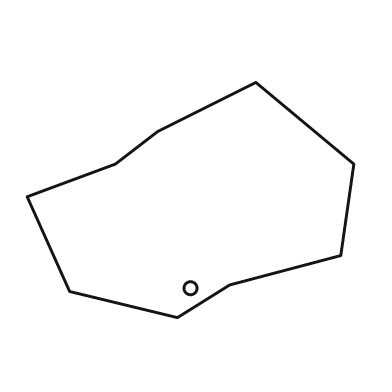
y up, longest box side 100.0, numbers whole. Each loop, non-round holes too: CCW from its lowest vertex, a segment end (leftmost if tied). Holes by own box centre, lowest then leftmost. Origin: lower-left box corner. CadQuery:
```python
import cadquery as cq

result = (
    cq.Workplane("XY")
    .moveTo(46.0, 0.0)
    .lineTo(62.0, 10.0)
    .lineTo(96.0, 19.0)
    .lineTo(100.0, 47.0)
    .lineTo(70.0, 72.0)
    .lineTo(40.0, 57.0)
    .lineTo(27.0, 47.0)
    .lineTo(0.0, 37.0)
    .lineTo(13.0, 8.0)
    .close()
    .moveTo(50.0, 9.0)
    .circle(2.0)
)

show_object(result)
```